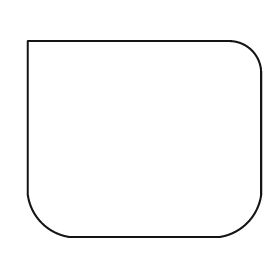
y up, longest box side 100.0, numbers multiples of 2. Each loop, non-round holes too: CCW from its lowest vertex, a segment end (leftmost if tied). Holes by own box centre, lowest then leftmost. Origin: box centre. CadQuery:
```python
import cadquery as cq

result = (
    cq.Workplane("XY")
    .moveTo(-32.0, -42.0)
    .lineTo(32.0, -42.0)
    .threePointArc((44.0, -36.0), (50.0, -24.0))
    .lineTo(50.0, 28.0)
    .threePointArc((46.0, 38.0), (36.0, 42.0))
    .lineTo(-50.0, 42.0)
    .lineTo(-50.0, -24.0)
    .threePointArc((-44.0, -36.0), (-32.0, -42.0))
    .close()
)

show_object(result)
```